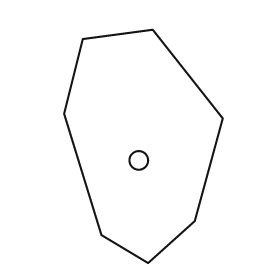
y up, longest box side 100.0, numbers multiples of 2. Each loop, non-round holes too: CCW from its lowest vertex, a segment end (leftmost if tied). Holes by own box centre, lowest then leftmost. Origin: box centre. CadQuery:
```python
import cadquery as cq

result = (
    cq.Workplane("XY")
    .moveTo(2.0, -50.0)
    .lineTo(22.0, -32.0)
    .lineTo(34.0, 12.0)
    .lineTo(4.0, 50.0)
    .lineTo(-26.0, 46.0)
    .lineTo(-34.0, 14.0)
    .lineTo(-18.0, -38.0)
    .close()
    .moveTo(-2.0, -6.0)
    .circle(4.0)
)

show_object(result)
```